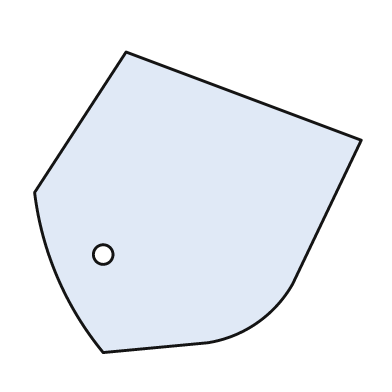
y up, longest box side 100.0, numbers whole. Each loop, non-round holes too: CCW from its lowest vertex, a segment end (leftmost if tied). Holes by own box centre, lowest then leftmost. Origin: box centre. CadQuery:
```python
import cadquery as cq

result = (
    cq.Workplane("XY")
    .moveTo(-29.0, -46.0)
    .lineTo(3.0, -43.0)
    .threePointArc((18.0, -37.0), (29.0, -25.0))
    .lineTo(50.0, 19.0)
    .lineTo(-22.0, 46.0)
    .lineTo(-50.0, 3.0)
    .threePointArc((-43.0, -23.0), (-29.0, -46.0))
    .close()
    .moveTo(-29.0, -16.0)
    .circle(3.0)
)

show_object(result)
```